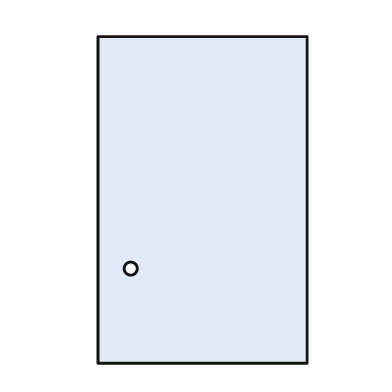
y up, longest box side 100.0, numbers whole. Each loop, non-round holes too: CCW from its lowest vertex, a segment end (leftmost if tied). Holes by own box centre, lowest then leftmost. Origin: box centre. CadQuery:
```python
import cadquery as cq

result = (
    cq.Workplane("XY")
    .moveTo(-32.0, -50.0)
    .lineTo(32.0, -50.0)
    .lineTo(32.0, 50.0)
    .lineTo(-32.0, 50.0)
    .close()
    .moveTo(-22.0, -21.0)
    .circle(2.0)
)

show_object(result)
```